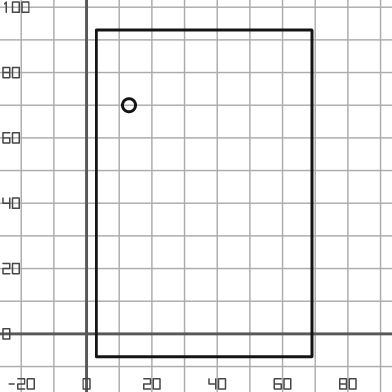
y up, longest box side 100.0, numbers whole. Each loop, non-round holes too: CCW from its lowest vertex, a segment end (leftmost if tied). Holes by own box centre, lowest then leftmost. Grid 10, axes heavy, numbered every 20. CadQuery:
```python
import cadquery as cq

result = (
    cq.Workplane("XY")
    .moveTo(3.0, -7.0)
    .lineTo(69.0, -7.0)
    .lineTo(69.0, 93.0)
    .lineTo(3.0, 93.0)
    .close()
    .moveTo(13.0, 70.0)
    .circle(2.0)
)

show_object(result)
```